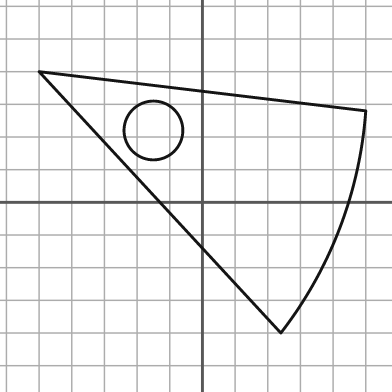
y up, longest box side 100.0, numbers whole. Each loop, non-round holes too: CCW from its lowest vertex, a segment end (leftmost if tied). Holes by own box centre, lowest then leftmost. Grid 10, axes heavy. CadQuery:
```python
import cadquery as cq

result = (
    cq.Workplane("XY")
    .moveTo(24.0, -40.0)
    .threePointArc((42.0, -8.0), (50.0, 28.0))
    .lineTo(-50.0, 40.0)
    .close()
    .moveTo(-15.0, 22.0)
    .circle(9.0)
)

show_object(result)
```